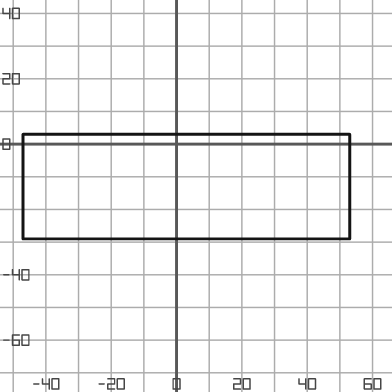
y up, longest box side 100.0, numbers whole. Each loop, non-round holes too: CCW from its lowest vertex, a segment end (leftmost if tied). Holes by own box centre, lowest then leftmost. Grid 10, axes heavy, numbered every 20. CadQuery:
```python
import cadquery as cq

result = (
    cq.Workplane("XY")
    .moveTo(-47.0, -29.0)
    .lineTo(53.0, -29.0)
    .lineTo(53.0, 3.0)
    .lineTo(-47.0, 3.0)
    .close()
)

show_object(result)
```